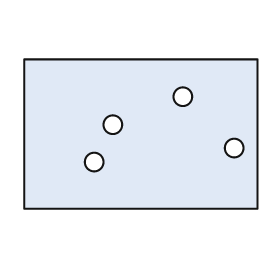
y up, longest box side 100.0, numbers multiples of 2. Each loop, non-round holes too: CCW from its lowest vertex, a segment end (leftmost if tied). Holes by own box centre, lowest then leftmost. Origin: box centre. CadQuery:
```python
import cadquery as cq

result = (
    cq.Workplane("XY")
    .moveTo(-50.0, -32.0)
    .lineTo(50.0, -32.0)
    .lineTo(50.0, 32.0)
    .lineTo(-50.0, 32.0)
    .close()
    .moveTo(-20.0, -12.0)
    .circle(4.0)
    .moveTo(40.0, -6.0)
    .circle(4.0)
    .moveTo(-12.0, 4.0)
    .circle(4.0)
    .moveTo(18.0, 16.0)
    .circle(4.0)
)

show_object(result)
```